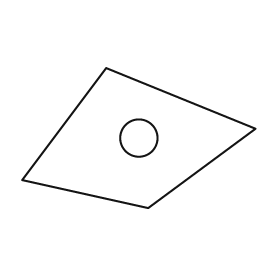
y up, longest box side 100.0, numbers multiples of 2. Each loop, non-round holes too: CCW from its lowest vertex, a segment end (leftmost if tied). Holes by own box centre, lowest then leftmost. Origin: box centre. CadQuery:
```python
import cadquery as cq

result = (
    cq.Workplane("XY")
    .moveTo(4.0, -30.0)
    .lineTo(50.0, 4.0)
    .lineTo(-14.0, 30.0)
    .lineTo(-50.0, -18.0)
    .close()
    .moveTo(0.0, 0.0)
    .circle(8.0)
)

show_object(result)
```